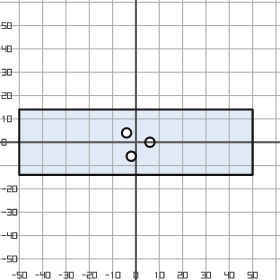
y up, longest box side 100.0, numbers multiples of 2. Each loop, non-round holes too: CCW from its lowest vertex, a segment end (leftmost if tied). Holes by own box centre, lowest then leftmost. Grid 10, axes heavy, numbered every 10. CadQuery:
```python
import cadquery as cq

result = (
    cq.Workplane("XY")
    .moveTo(-50.0, -14.0)
    .lineTo(50.0, -14.0)
    .lineTo(50.0, 14.0)
    .lineTo(-50.0, 14.0)
    .close()
    .moveTo(-2.0, -6.0)
    .circle(2.0)
    .moveTo(6.0, 0.0)
    .circle(2.0)
    .moveTo(-4.0, 4.0)
    .circle(2.0)
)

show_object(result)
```